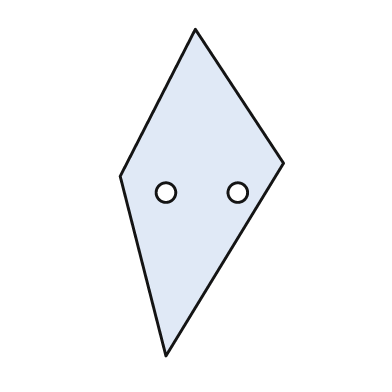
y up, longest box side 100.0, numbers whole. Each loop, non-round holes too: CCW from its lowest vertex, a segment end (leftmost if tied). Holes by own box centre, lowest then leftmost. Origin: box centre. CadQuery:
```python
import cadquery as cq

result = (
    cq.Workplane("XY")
    .moveTo(-11.0, -50.0)
    .lineTo(25.0, 9.0)
    .lineTo(-2.0, 50.0)
    .lineTo(-25.0, 5.0)
    .close()
    .moveTo(-11.0, 0.0)
    .circle(3.0)
    .moveTo(11.0, 0.0)
    .circle(3.0)
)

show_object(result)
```